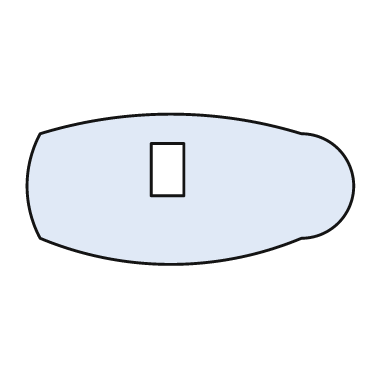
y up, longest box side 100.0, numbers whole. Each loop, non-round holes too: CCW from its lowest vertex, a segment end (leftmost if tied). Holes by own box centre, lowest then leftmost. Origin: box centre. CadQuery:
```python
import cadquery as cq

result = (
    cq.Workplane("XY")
    .moveTo(-46.0, -15.0)
    .threePointArc((-6.0, -23.0), (34.0, -15.0))
    .threePointArc((50.0, 1.0), (34.0, 17.0))
    .threePointArc((-6.0, 23.0), (-46.0, 17.0))
    .threePointArc((-50.0, 1.0), (-46.0, -15.0))
    .close()
    .moveTo(-12.0, -2.0)
    .lineTo(-2.0, -2.0)
    .lineTo(-2.0, 14.0)
    .lineTo(-12.0, 14.0)
    .close()
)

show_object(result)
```